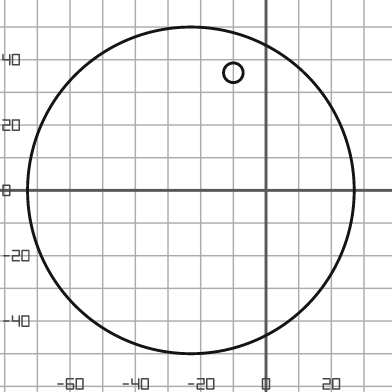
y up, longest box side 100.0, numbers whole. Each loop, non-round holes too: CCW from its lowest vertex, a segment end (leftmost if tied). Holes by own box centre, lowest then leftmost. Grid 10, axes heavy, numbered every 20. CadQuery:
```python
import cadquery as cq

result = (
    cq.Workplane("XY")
    .moveTo(-23.0, 0.0)
    .circle(50.0)
    .moveTo(-10.0, 36.0)
    .circle(3.0)
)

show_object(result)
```